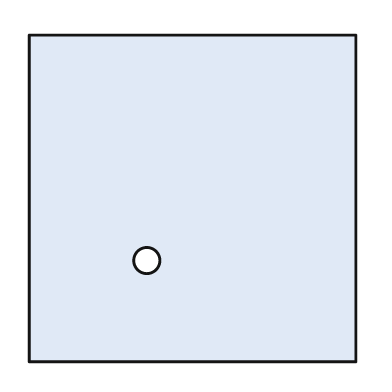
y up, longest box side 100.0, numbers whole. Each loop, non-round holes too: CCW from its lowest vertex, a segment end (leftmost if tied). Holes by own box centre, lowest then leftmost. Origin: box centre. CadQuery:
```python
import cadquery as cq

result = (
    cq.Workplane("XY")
    .moveTo(-50.0, -50.0)
    .lineTo(50.0, -50.0)
    .lineTo(50.0, 50.0)
    .lineTo(-50.0, 50.0)
    .close()
    .moveTo(-14.0, -19.0)
    .circle(4.0)
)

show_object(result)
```